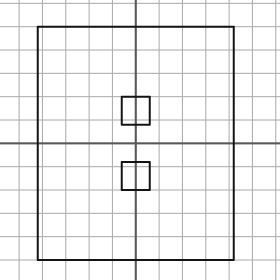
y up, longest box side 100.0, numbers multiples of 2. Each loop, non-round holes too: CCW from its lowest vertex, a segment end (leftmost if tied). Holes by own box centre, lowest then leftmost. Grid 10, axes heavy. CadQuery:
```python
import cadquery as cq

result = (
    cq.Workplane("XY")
    .moveTo(-42.0, -50.0)
    .lineTo(42.0, -50.0)
    .lineTo(42.0, 50.0)
    .lineTo(-42.0, 50.0)
    .close()
    .moveTo(-6.0, -20.0)
    .lineTo(6.0, -20.0)
    .lineTo(6.0, -8.0)
    .lineTo(-6.0, -8.0)
    .close()
    .moveTo(-6.0, 8.0)
    .lineTo(6.0, 8.0)
    .lineTo(6.0, 20.0)
    .lineTo(-6.0, 20.0)
    .close()
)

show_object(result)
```